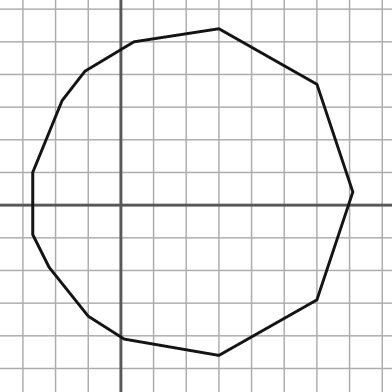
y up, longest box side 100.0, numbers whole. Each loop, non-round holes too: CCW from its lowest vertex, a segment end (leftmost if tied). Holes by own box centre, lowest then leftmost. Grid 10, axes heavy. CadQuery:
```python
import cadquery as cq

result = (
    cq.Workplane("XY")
    .moveTo(30.0, -46.0)
    .lineTo(60.0, -29.0)
    .lineTo(71.0, 4.0)
    .lineTo(60.0, 37.0)
    .lineTo(30.0, 54.0)
    .lineTo(4.0, 50.0)
    .lineTo(-11.0, 41.0)
    .lineTo(-18.0, 32.0)
    .lineTo(-27.0, 10.0)
    .lineTo(-27.0, -9.0)
    .lineTo(-22.0, -19.0)
    .lineTo(-10.0, -34.0)
    .lineTo(1.0, -41.0)
    .close()
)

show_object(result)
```